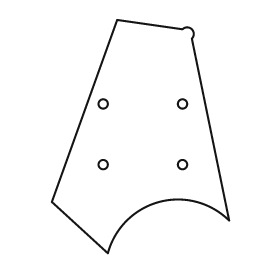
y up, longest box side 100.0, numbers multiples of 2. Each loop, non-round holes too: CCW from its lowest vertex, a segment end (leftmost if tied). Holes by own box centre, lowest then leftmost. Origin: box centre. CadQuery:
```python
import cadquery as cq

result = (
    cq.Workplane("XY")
    .moveTo(-14.0, -50.0)
    .threePointArc((8.0, -28.0), (38.0, -36.0))
    .lineTo(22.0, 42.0)
    .threePointArc((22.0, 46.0), (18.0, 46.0))
    .lineTo(-10.0, 50.0)
    .lineTo(-38.0, -28.0)
    .close()
    .moveTo(-16.0, -12.0)
    .circle(2.0)
    .moveTo(18.0, -12.0)
    .circle(2.0)
    .moveTo(-16.0, 14.0)
    .circle(2.0)
    .moveTo(18.0, 14.0)
    .circle(2.0)
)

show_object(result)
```